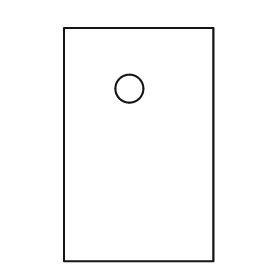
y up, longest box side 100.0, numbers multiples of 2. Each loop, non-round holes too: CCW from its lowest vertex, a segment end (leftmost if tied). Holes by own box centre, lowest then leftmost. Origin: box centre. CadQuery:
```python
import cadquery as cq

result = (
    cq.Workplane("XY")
    .moveTo(-32.0, -50.0)
    .lineTo(32.0, -50.0)
    .lineTo(32.0, 50.0)
    .lineTo(-32.0, 50.0)
    .close()
    .moveTo(-4.0, 24.0)
    .circle(6.0)
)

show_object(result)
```